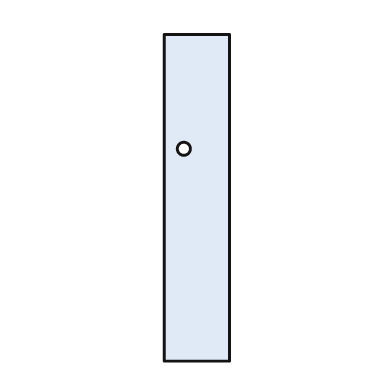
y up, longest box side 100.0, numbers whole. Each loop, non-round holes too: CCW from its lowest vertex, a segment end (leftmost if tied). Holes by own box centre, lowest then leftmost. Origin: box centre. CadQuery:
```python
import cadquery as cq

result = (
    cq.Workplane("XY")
    .moveTo(-10.0, -50.0)
    .lineTo(10.0, -50.0)
    .lineTo(10.0, 50.0)
    .lineTo(-10.0, 50.0)
    .close()
    .moveTo(-4.0, 15.0)
    .circle(2.0)
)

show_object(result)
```